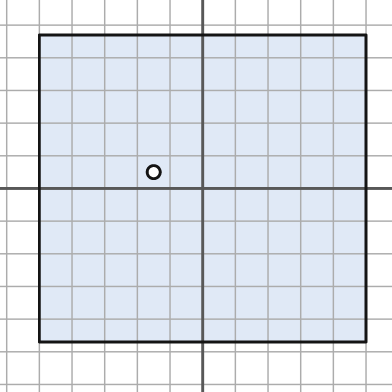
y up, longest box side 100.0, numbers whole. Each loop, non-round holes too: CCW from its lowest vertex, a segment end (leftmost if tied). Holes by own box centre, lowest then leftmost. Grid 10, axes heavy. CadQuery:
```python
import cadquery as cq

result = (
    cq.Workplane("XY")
    .moveTo(-50.0, -47.0)
    .lineTo(50.0, -47.0)
    .lineTo(50.0, 47.0)
    .lineTo(-50.0, 47.0)
    .close()
    .moveTo(-15.0, 5.0)
    .circle(2.0)
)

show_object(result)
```